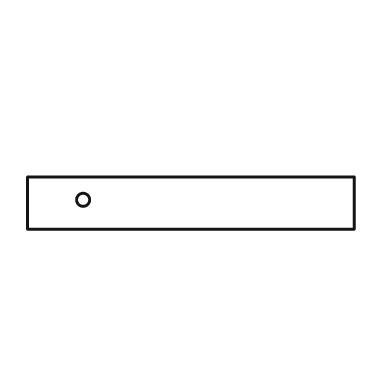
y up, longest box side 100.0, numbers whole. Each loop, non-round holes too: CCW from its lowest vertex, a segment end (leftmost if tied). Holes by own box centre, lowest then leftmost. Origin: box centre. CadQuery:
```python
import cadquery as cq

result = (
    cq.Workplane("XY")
    .moveTo(-50.0, -8.0)
    .lineTo(50.0, -8.0)
    .lineTo(50.0, 8.0)
    .lineTo(-50.0, 8.0)
    .close()
    .moveTo(-33.0, 1.0)
    .circle(2.0)
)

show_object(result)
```